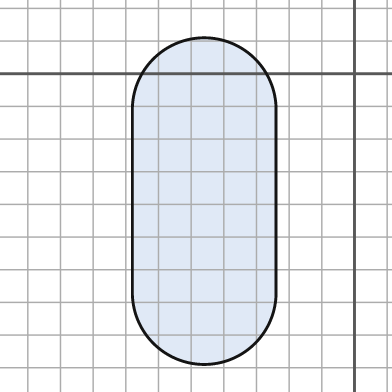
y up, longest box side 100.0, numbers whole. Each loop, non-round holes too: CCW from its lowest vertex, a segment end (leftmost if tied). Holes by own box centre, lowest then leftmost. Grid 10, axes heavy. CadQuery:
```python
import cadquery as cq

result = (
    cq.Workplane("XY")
    .moveTo(-68.0, -67.0)
    .threePointArc((-46.0, -89.0), (-24.0, -67.0))
    .lineTo(-24.0, -11.0)
    .threePointArc((-46.0, 11.0), (-68.0, -11.0))
    .close()
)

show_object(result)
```